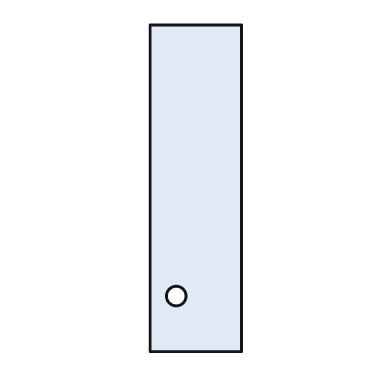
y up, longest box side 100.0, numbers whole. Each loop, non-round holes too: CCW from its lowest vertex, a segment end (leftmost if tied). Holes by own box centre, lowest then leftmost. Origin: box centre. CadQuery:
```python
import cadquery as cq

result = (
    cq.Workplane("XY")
    .moveTo(-14.0, -50.0)
    .lineTo(14.0, -50.0)
    .lineTo(14.0, 50.0)
    .lineTo(-14.0, 50.0)
    .close()
    .moveTo(-6.0, -33.0)
    .circle(3.0)
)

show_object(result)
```